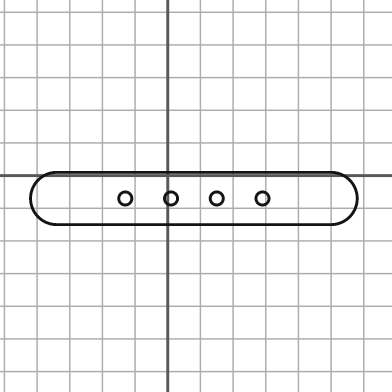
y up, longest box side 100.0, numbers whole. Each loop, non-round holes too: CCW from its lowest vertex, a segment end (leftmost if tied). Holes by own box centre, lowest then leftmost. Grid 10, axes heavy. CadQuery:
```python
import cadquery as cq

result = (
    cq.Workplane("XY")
    .moveTo(-34.0, -15.0)
    .lineTo(50.0, -15.0)
    .threePointArc((58.0, -7.0), (50.0, 1.0))
    .lineTo(-34.0, 1.0)
    .threePointArc((-42.0, -7.0), (-34.0, -15.0))
    .close()
    .moveTo(-13.0, -7.0)
    .circle(2.0)
    .moveTo(1.0, -7.0)
    .circle(2.0)
    .moveTo(15.0, -7.0)
    .circle(2.0)
    .moveTo(29.0, -7.0)
    .circle(2.0)
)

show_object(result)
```